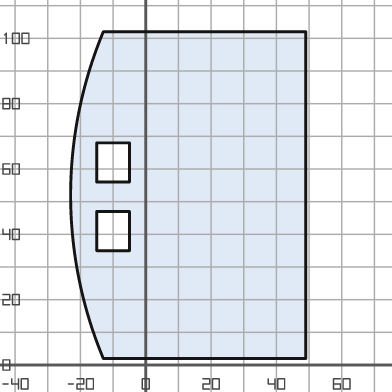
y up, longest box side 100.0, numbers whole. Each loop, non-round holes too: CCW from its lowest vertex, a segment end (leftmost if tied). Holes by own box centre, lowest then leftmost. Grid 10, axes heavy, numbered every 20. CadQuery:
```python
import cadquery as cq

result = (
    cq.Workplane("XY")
    .moveTo(-13.0, 2.0)
    .lineTo(49.0, 2.0)
    .lineTo(49.0, 102.0)
    .lineTo(-13.0, 102.0)
    .threePointArc((-23.0, 52.0), (-13.0, 2.0))
    .close()
    .moveTo(-15.0, 35.0)
    .lineTo(-5.0, 35.0)
    .lineTo(-5.0, 47.0)
    .lineTo(-15.0, 47.0)
    .close()
    .moveTo(-15.0, 56.0)
    .lineTo(-5.0, 56.0)
    .lineTo(-5.0, 68.0)
    .lineTo(-15.0, 68.0)
    .close()
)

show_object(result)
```